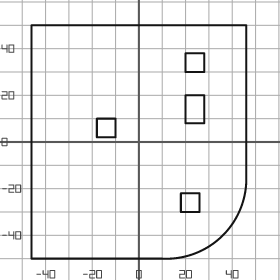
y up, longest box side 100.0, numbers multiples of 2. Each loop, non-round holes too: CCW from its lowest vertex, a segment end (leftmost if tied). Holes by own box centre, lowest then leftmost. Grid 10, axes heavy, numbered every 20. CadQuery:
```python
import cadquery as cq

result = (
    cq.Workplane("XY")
    .moveTo(-46.0, -50.0)
    .lineTo(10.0, -50.0)
    .threePointArc((36.0, -40.0), (46.0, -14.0))
    .lineTo(46.0, 50.0)
    .lineTo(-46.0, 50.0)
    .close()
    .moveTo(18.0, -30.0)
    .lineTo(26.0, -30.0)
    .lineTo(26.0, -22.0)
    .lineTo(18.0, -22.0)
    .close()
    .moveTo(-18.0, 2.0)
    .lineTo(-10.0, 2.0)
    .lineTo(-10.0, 10.0)
    .lineTo(-18.0, 10.0)
    .close()
    .moveTo(20.0, 8.0)
    .lineTo(28.0, 8.0)
    .lineTo(28.0, 20.0)
    .lineTo(20.0, 20.0)
    .close()
    .moveTo(20.0, 30.0)
    .lineTo(28.0, 30.0)
    .lineTo(28.0, 38.0)
    .lineTo(20.0, 38.0)
    .close()
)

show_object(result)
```